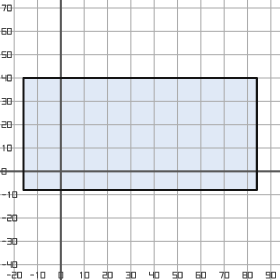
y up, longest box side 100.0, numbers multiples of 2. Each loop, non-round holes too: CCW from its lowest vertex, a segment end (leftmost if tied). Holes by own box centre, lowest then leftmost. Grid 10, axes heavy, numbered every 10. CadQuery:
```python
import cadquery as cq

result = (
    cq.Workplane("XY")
    .moveTo(-16.0, -8.0)
    .lineTo(84.0, -8.0)
    .lineTo(84.0, 40.0)
    .lineTo(-16.0, 40.0)
    .close()
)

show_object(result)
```